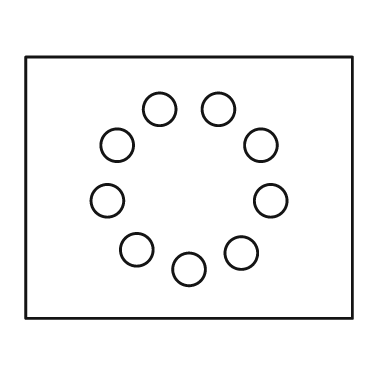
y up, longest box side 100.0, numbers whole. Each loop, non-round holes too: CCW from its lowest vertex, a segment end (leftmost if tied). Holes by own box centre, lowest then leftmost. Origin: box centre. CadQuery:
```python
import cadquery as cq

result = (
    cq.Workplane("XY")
    .moveTo(-50.0, -40.0)
    .lineTo(50.0, -40.0)
    .lineTo(50.0, 40.0)
    .lineTo(-50.0, 40.0)
    .close()
    .moveTo(0.0, -25.0)
    .circle(5.0)
    .moveTo(16.0, -20.0)
    .circle(5.0)
    .moveTo(-16.0, -19.0)
    .circle(5.0)
    .moveTo(-25.0, -4.0)
    .circle(5.0)
    .moveTo(25.0, -4.0)
    .circle(5.0)
    .moveTo(-22.0, 13.0)
    .circle(5.0)
    .moveTo(22.0, 13.0)
    .circle(5.0)
    .moveTo(-9.0, 24.0)
    .circle(5.0)
    .moveTo(9.0, 24.0)
    .circle(5.0)
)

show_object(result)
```